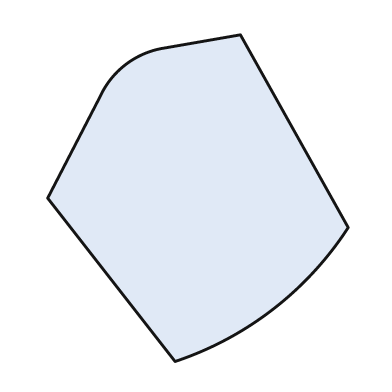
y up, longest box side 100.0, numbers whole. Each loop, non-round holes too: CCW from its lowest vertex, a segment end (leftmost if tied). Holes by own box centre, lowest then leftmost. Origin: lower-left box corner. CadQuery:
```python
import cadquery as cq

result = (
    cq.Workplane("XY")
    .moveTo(39.0, 0.0)
    .threePointArc((69.0, 16.0), (92.0, 41.0))
    .lineTo(59.0, 100.0)
    .lineTo(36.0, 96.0)
    .threePointArc((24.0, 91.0), (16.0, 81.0))
    .lineTo(0.0, 50.0)
    .close()
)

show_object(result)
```